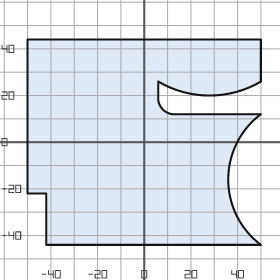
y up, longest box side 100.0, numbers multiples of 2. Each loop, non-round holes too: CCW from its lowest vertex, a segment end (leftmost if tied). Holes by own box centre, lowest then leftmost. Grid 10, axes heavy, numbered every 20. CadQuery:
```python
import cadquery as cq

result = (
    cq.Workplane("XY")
    .moveTo(-42.0, -44.0)
    .lineTo(50.0, -44.0)
    .threePointArc((36.0, -16.0), (50.0, 12.0))
    .lineTo(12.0, 12.0)
    .threePointArc((8.0, 14.0), (6.0, 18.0))
    .lineTo(6.0, 26.0)
    .threePointArc((28.0, 20.0), (50.0, 26.0))
    .lineTo(50.0, 44.0)
    .lineTo(-50.0, 44.0)
    .lineTo(-50.0, -22.0)
    .lineTo(-42.0, -22.0)
    .close()
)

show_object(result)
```